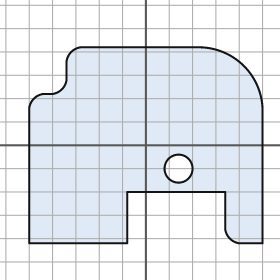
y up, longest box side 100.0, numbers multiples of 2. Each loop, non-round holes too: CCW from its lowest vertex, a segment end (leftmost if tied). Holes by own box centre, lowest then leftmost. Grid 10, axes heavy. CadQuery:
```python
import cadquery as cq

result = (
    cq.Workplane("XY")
    .moveTo(-50.0, -42.0)
    .lineTo(-8.0, -42.0)
    .lineTo(-8.0, -20.0)
    .lineTo(34.0, -20.0)
    .lineTo(34.0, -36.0)
    .threePointArc((36.0, -40.0), (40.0, -42.0))
    .lineTo(50.0, -42.0)
    .lineTo(50.0, 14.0)
    .threePointArc((42.0, 34.0), (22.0, 42.0))
    .lineTo(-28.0, 42.0)
    .threePointArc((-32.0, 40.0), (-34.0, 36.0))
    .lineTo(-34.0, 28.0)
    .threePointArc((-36.0, 24.0), (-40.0, 22.0))
    .lineTo(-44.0, 22.0)
    .threePointArc((-48.0, 20.0), (-50.0, 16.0))
    .close()
    .moveTo(14.0, -10.0)
    .circle(6.0)
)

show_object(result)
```